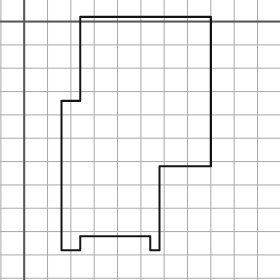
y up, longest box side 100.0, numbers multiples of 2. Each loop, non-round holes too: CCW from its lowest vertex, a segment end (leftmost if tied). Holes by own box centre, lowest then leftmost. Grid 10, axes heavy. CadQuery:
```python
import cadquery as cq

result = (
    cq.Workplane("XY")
    .moveTo(16.0, -98.0)
    .lineTo(24.0, -98.0)
    .lineTo(24.0, -92.0)
    .lineTo(54.0, -92.0)
    .lineTo(54.0, -98.0)
    .lineTo(58.0, -98.0)
    .lineTo(58.0, -62.0)
    .lineTo(80.0, -62.0)
    .lineTo(80.0, 2.0)
    .lineTo(24.0, 2.0)
    .lineTo(24.0, -34.0)
    .lineTo(16.0, -34.0)
    .close()
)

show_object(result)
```